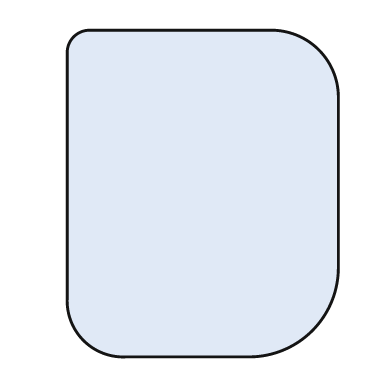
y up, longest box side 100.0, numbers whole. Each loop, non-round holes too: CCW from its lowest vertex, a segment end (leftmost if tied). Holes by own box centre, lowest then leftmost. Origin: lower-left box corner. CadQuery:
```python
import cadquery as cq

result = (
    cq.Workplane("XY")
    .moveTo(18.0, 0.0)
    .lineTo(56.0, 0.0)
    .threePointArc((75.0, 8.0), (83.0, 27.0))
    .lineTo(83.0, 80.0)
    .threePointArc((77.0, 94.0), (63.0, 100.0))
    .lineTo(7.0, 100.0)
    .threePointArc((2.0, 98.0), (0.0, 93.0))
    .lineTo(0.0, 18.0)
    .threePointArc((5.0, 5.0), (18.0, 0.0))
    .close()
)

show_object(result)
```